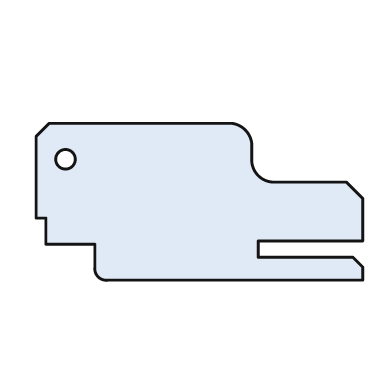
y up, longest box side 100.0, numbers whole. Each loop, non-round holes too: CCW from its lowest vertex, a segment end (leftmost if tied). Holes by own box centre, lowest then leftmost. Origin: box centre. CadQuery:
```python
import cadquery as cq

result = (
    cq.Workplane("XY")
    .moveTo(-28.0, -24.0)
    .lineTo(50.0, -24.0)
    .lineTo(50.0, -20.0)
    .lineTo(47.0, -17.0)
    .lineTo(18.0, -17.0)
    .lineTo(18.0, -12.0)
    .lineTo(50.0, -12.0)
    .lineTo(50.0, 1.0)
    .lineTo(45.0, 6.0)
    .lineTo(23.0, 6.0)
    .threePointArc((18.0, 8.0), (16.0, 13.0))
    .lineTo(16.0, 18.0)
    .threePointArc((14.0, 22.0), (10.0, 24.0))
    .lineTo(-46.0, 24.0)
    .lineTo(-50.0, 20.0)
    .lineTo(-50.0, -5.0)
    .lineTo(-47.0, -5.0)
    .lineTo(-47.0, -13.0)
    .lineTo(-32.0, -13.0)
    .lineTo(-32.0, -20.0)
    .threePointArc((-31.0, -23.0), (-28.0, -24.0))
    .close()
    .moveTo(-41.0, 13.0)
    .circle(3.0)
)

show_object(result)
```